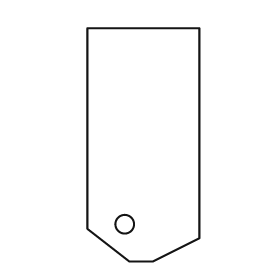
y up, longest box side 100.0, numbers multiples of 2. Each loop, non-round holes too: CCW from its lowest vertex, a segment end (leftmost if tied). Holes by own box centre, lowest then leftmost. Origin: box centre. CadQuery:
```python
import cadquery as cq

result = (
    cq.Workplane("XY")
    .moveTo(-6.0, -50.0)
    .lineTo(4.0, -50.0)
    .lineTo(24.0, -40.0)
    .lineTo(24.0, 50.0)
    .lineTo(-24.0, 50.0)
    .lineTo(-24.0, -36.0)
    .close()
    .moveTo(-8.0, -34.0)
    .circle(4.0)
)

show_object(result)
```